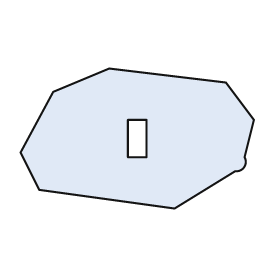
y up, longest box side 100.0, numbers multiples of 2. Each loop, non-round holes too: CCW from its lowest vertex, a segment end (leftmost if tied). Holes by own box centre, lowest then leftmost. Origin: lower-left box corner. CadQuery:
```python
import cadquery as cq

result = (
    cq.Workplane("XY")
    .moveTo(66.0, 0.0)
    .lineTo(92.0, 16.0)
    .threePointArc((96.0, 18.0), (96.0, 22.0))
    .lineTo(100.0, 38.0)
    .lineTo(88.0, 54.0)
    .lineTo(38.0, 60.0)
    .lineTo(14.0, 50.0)
    .lineTo(0.0, 24.0)
    .lineTo(8.0, 8.0)
    .close()
    .moveTo(46.0, 22.0)
    .lineTo(54.0, 22.0)
    .lineTo(54.0, 38.0)
    .lineTo(46.0, 38.0)
    .close()
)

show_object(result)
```